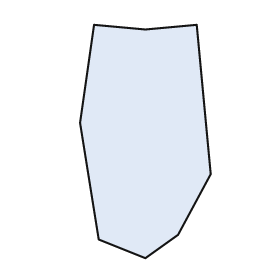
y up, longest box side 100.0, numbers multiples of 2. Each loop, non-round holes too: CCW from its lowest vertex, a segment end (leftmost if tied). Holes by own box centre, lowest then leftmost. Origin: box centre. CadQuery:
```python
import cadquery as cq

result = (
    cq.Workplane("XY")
    .moveTo(0.0, -50.0)
    .lineTo(14.0, -40.0)
    .lineTo(28.0, -14.0)
    .lineTo(22.0, 50.0)
    .lineTo(0.0, 48.0)
    .lineTo(-22.0, 50.0)
    .lineTo(-28.0, 8.0)
    .lineTo(-20.0, -42.0)
    .close()
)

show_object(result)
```